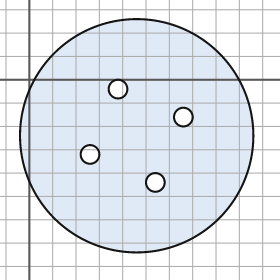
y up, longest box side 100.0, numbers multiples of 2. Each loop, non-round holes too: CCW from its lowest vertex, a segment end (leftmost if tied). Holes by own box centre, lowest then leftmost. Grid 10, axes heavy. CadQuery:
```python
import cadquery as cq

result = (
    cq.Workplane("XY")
    .moveTo(46.0, -24.0)
    .circle(50.0)
    .moveTo(54.0, -44.0)
    .circle(4.0)
    .moveTo(26.0, -32.0)
    .circle(4.0)
    .moveTo(66.0, -16.0)
    .circle(4.0)
    .moveTo(38.0, -4.0)
    .circle(4.0)
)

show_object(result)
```